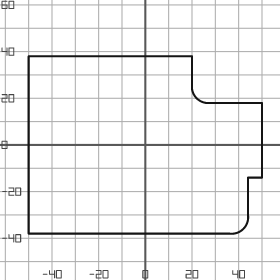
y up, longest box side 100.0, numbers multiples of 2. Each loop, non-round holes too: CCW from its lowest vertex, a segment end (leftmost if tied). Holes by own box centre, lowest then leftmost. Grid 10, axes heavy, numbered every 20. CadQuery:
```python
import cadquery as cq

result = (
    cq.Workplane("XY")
    .moveTo(-50.0, -38.0)
    .lineTo(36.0, -38.0)
    .threePointArc((42.0, -36.0), (44.0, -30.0))
    .lineTo(44.0, -14.0)
    .lineTo(50.0, -14.0)
    .lineTo(50.0, 18.0)
    .lineTo(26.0, 18.0)
    .threePointArc((22.0, 20.0), (20.0, 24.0))
    .lineTo(20.0, 38.0)
    .lineTo(-50.0, 38.0)
    .close()
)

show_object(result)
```